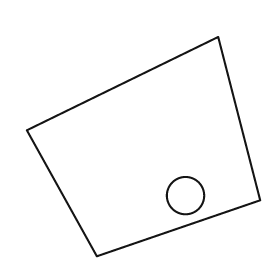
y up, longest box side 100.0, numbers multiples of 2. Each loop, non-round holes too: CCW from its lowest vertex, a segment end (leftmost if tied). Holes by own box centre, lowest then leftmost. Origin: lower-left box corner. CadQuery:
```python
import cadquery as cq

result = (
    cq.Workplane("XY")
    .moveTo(30.0, 0.0)
    .lineTo(100.0, 24.0)
    .lineTo(82.0, 94.0)
    .lineTo(0.0, 54.0)
    .close()
    .moveTo(68.0, 26.0)
    .circle(8.0)
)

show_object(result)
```